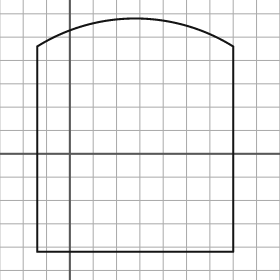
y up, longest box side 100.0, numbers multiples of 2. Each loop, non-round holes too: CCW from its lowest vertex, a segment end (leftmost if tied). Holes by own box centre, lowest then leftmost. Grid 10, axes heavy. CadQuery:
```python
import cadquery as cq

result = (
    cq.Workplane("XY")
    .moveTo(-14.0, -42.0)
    .lineTo(70.0, -42.0)
    .lineTo(70.0, 46.0)
    .threePointArc((28.0, 58.0), (-14.0, 46.0))
    .close()
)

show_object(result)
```